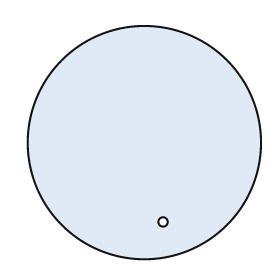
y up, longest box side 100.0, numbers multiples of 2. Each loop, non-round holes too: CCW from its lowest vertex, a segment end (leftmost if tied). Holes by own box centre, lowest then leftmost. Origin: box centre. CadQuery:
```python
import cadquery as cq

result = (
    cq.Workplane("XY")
    .moveTo(0.0, 0.0)
    .circle(50.0)
    .moveTo(8.0, -34.0)
    .circle(2.0)
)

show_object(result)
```